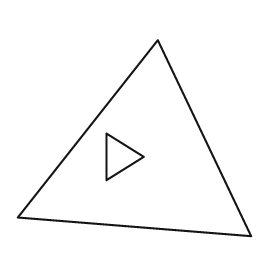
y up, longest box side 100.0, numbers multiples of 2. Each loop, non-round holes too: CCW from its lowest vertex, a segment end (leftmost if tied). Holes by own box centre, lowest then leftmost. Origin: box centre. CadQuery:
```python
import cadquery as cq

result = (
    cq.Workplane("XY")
    .moveTo(50.0, -42.0)
    .lineTo(10.0, 42.0)
    .lineTo(-50.0, -34.0)
    .close()
    .moveTo(-12.0, -18.0)
    .lineTo(4.0, -8.0)
    .lineTo(-12.0, 2.0)
    .close()
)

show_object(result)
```